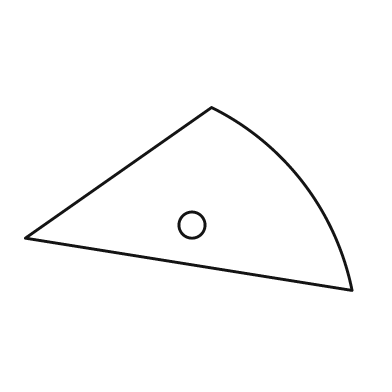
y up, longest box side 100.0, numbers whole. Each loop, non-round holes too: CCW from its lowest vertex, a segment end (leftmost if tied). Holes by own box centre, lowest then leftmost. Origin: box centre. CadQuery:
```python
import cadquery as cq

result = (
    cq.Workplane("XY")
    .moveTo(50.0, -28.0)
    .threePointArc((35.0, 5.0), (7.0, 28.0))
    .lineTo(-50.0, -12.0)
    .close()
    .moveTo(1.0, -8.0)
    .circle(4.0)
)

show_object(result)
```